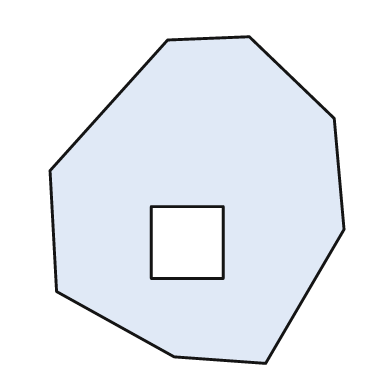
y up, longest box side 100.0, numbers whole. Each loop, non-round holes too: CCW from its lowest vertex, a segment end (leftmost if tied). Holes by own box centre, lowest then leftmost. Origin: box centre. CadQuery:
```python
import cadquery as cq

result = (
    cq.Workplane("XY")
    .moveTo(21.0, -50.0)
    .lineTo(45.0, -9.0)
    .lineTo(42.0, 25.0)
    .lineTo(16.0, 50.0)
    .lineTo(-9.0, 49.0)
    .lineTo(-45.0, 9.0)
    .lineTo(-43.0, -28.0)
    .lineTo(-7.0, -48.0)
    .close()
    .moveTo(-14.0, -24.0)
    .lineTo(8.0, -24.0)
    .lineTo(8.0, -2.0)
    .lineTo(-14.0, -2.0)
    .close()
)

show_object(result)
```